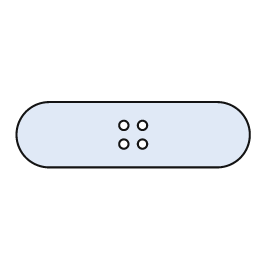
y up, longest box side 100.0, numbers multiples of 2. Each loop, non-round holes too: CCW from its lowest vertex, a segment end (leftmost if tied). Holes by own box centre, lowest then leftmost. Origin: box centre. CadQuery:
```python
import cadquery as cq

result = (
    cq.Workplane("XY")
    .moveTo(-36.0, -14.0)
    .lineTo(36.0, -14.0)
    .threePointArc((50.0, 0.0), (36.0, 14.0))
    .lineTo(-36.0, 14.0)
    .threePointArc((-50.0, 0.0), (-36.0, -14.0))
    .close()
    .moveTo(-4.0, -4.0)
    .circle(2.0)
    .moveTo(4.0, -4.0)
    .circle(2.0)
    .moveTo(-4.0, 4.0)
    .circle(2.0)
    .moveTo(4.0, 4.0)
    .circle(2.0)
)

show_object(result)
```